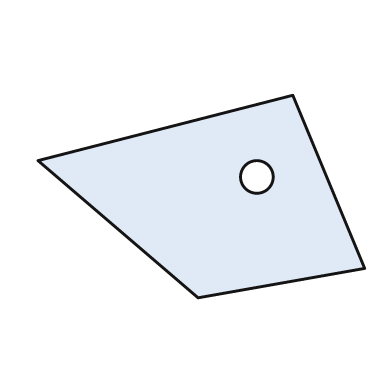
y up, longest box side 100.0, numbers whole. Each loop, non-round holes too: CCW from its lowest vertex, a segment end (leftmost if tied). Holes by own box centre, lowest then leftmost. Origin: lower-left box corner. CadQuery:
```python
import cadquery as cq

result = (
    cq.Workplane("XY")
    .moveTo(49.0, 0.0)
    .lineTo(100.0, 9.0)
    .lineTo(78.0, 62.0)
    .lineTo(0.0, 42.0)
    .close()
    .moveTo(67.0, 37.0)
    .circle(5.0)
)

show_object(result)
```